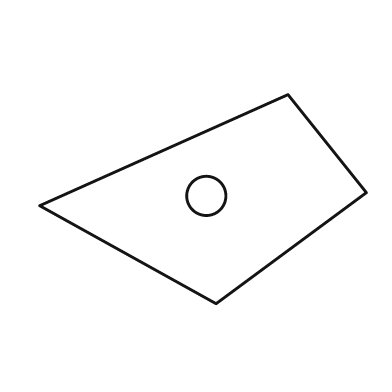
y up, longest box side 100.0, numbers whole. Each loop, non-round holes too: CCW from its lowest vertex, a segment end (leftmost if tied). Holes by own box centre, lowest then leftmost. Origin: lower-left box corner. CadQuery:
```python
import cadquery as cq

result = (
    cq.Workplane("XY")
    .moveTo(54.0, 0.0)
    .lineTo(100.0, 34.0)
    .lineTo(76.0, 64.0)
    .lineTo(0.0, 30.0)
    .close()
    .moveTo(51.0, 33.0)
    .circle(6.0)
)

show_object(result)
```